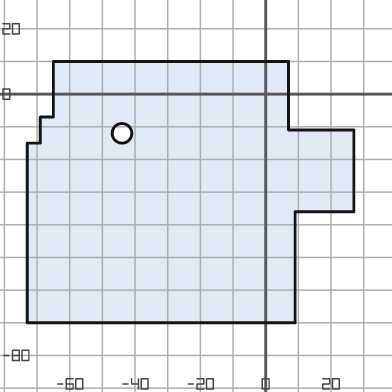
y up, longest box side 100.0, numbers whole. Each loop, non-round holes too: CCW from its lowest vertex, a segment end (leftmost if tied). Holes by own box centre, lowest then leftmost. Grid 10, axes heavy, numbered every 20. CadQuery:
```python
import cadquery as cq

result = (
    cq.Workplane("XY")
    .moveTo(-73.0, -70.0)
    .lineTo(9.0, -70.0)
    .lineTo(9.0, -36.0)
    .lineTo(27.0, -36.0)
    .lineTo(27.0, -11.0)
    .lineTo(7.0, -11.0)
    .lineTo(7.0, 10.0)
    .lineTo(-65.0, 10.0)
    .lineTo(-65.0, -7.0)
    .lineTo(-69.0, -7.0)
    .lineTo(-69.0, -15.0)
    .lineTo(-73.0, -15.0)
    .close()
    .moveTo(-44.0, -12.0)
    .circle(3.0)
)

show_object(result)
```